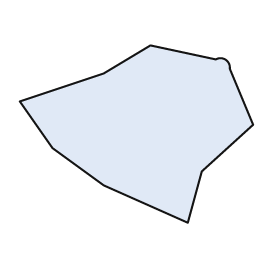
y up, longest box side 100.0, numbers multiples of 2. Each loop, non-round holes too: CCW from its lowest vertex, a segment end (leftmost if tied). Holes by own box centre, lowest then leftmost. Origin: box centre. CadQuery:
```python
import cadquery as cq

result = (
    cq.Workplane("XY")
    .moveTo(22.0, -38.0)
    .lineTo(28.0, -16.0)
    .lineTo(50.0, 4.0)
    .lineTo(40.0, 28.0)
    .threePointArc((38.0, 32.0), (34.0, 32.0))
    .lineTo(6.0, 38.0)
    .lineTo(-14.0, 26.0)
    .lineTo(-50.0, 14.0)
    .lineTo(-36.0, -6.0)
    .lineTo(-14.0, -22.0)
    .close()
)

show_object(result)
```